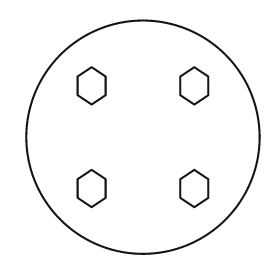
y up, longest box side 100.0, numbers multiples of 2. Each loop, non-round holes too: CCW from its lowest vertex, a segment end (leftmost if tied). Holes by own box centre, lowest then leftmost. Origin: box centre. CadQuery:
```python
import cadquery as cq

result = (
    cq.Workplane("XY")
    .moveTo(0.0, 0.0)
    .circle(50.0)
    .moveTo(-22.0, -30.0)
    .lineTo(-16.0, -26.0)
    .lineTo(-16.0, -18.0)
    .lineTo(-22.0, -14.0)
    .lineTo(-28.0, -18.0)
    .lineTo(-28.0, -26.0)
    .close()
    .moveTo(22.0, -30.0)
    .lineTo(28.0, -26.0)
    .lineTo(28.0, -18.0)
    .lineTo(22.0, -14.0)
    .lineTo(16.0, -18.0)
    .lineTo(16.0, -26.0)
    .close()
    .moveTo(-22.0, 14.0)
    .lineTo(-16.0, 18.0)
    .lineTo(-16.0, 26.0)
    .lineTo(-22.0, 30.0)
    .lineTo(-28.0, 26.0)
    .lineTo(-28.0, 18.0)
    .close()
    .moveTo(22.0, 14.0)
    .lineTo(28.0, 18.0)
    .lineTo(28.0, 26.0)
    .lineTo(22.0, 30.0)
    .lineTo(16.0, 26.0)
    .lineTo(16.0, 18.0)
    .close()
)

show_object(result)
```